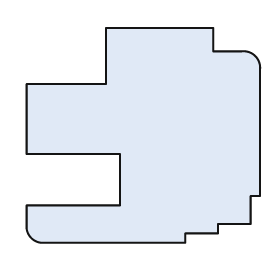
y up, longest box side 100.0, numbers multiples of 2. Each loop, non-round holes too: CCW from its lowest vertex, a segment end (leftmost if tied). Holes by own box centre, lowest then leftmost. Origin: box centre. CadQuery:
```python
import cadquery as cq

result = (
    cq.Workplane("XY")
    .moveTo(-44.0, -46.0)
    .lineTo(18.0, -46.0)
    .lineTo(18.0, -42.0)
    .lineTo(32.0, -42.0)
    .lineTo(32.0, -38.0)
    .lineTo(46.0, -38.0)
    .lineTo(46.0, -26.0)
    .lineTo(50.0, -26.0)
    .lineTo(50.0, 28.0)
    .threePointArc((48.0, 34.0), (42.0, 36.0))
    .lineTo(30.0, 36.0)
    .lineTo(30.0, 46.0)
    .lineTo(-16.0, 46.0)
    .lineTo(-16.0, 22.0)
    .lineTo(-50.0, 22.0)
    .lineTo(-50.0, -8.0)
    .lineTo(-10.0, -8.0)
    .lineTo(-10.0, -30.0)
    .lineTo(-50.0, -30.0)
    .lineTo(-50.0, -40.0)
    .threePointArc((-48.0, -44.0), (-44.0, -46.0))
    .close()
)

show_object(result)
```